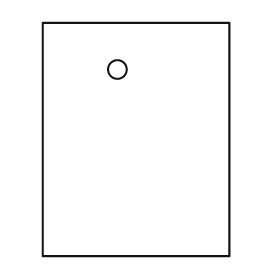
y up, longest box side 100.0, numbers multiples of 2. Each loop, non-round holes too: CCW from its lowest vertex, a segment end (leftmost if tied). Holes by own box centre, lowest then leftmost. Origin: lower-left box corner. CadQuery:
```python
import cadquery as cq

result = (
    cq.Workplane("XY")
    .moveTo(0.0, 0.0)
    .lineTo(80.0, 0.0)
    .lineTo(80.0, 100.0)
    .lineTo(0.0, 100.0)
    .close()
    .moveTo(32.0, 80.0)
    .circle(4.0)
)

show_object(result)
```